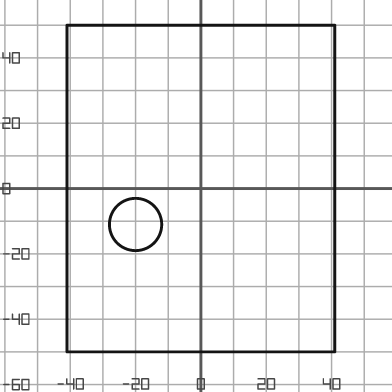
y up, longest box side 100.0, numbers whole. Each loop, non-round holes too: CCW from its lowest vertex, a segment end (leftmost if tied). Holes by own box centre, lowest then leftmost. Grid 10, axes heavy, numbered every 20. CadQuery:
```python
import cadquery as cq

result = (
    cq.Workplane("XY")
    .moveTo(-41.0, -50.0)
    .lineTo(41.0, -50.0)
    .lineTo(41.0, 50.0)
    .lineTo(-41.0, 50.0)
    .close()
    .moveTo(-20.0, -11.0)
    .circle(8.0)
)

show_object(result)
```